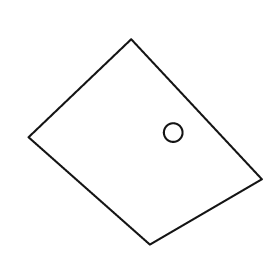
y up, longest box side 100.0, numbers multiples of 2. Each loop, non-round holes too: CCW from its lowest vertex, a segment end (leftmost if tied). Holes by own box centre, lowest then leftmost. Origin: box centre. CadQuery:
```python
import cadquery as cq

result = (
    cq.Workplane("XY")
    .moveTo(2.0, -44.0)
    .lineTo(50.0, -16.0)
    .lineTo(-6.0, 44.0)
    .lineTo(-50.0, 2.0)
    .close()
    .moveTo(12.0, 4.0)
    .circle(4.0)
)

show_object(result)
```